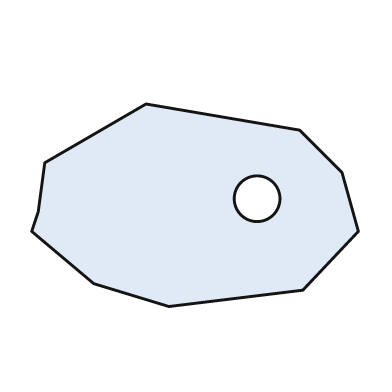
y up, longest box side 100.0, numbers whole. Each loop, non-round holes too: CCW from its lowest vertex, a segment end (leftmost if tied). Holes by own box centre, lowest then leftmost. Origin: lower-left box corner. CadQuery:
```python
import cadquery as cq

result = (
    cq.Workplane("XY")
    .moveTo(42.0, 0.0)
    .lineTo(83.0, 5.0)
    .lineTo(100.0, 23.0)
    .lineTo(95.0, 41.0)
    .lineTo(82.0, 54.0)
    .lineTo(35.0, 62.0)
    .lineTo(4.0, 44.0)
    .lineTo(2.0, 29.0)
    .lineTo(0.0, 23.0)
    .lineTo(19.0, 7.0)
    .close()
    .moveTo(69.0, 33.0)
    .circle(7.0)
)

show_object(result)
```